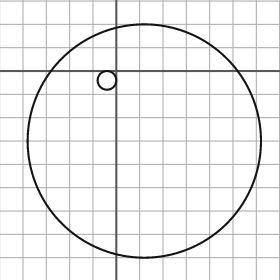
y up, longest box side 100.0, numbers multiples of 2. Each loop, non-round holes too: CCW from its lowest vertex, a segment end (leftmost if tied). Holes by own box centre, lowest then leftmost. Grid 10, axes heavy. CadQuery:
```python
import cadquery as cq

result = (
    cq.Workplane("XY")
    .moveTo(12.0, -30.0)
    .circle(50.0)
    .moveTo(-4.0, -4.0)
    .circle(4.0)
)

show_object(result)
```